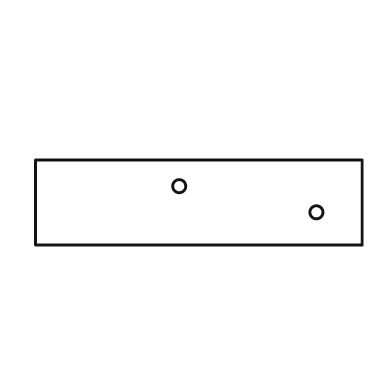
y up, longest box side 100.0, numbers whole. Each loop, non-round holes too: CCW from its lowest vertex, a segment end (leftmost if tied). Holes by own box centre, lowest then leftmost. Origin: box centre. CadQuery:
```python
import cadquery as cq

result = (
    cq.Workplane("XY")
    .moveTo(-50.0, -13.0)
    .lineTo(50.0, -13.0)
    .lineTo(50.0, 13.0)
    .lineTo(-50.0, 13.0)
    .close()
    .moveTo(36.0, -3.0)
    .circle(2.0)
    .moveTo(-6.0, 5.0)
    .circle(2.0)
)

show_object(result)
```